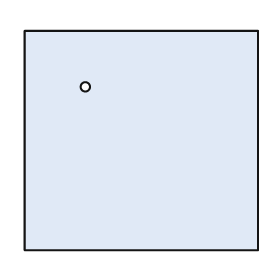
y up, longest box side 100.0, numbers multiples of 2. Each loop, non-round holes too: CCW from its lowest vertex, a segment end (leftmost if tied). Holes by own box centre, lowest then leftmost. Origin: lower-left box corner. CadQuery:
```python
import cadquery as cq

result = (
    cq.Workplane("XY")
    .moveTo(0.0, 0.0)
    .lineTo(100.0, 0.0)
    .lineTo(100.0, 94.0)
    .lineTo(0.0, 94.0)
    .close()
    .moveTo(26.0, 70.0)
    .circle(2.0)
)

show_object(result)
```